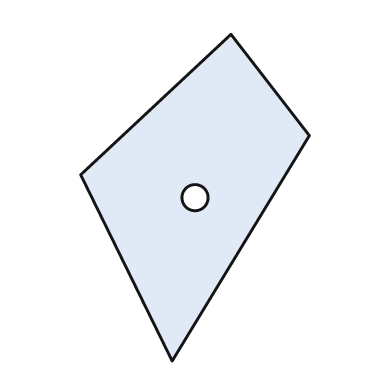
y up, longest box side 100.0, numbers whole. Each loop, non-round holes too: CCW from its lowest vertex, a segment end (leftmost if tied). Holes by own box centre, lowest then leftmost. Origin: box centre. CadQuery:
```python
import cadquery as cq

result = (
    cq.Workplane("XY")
    .moveTo(-7.0, -50.0)
    .lineTo(35.0, 19.0)
    .lineTo(11.0, 50.0)
    .lineTo(-35.0, 7.0)
    .close()
    .moveTo(0.0, 0.0)
    .circle(4.0)
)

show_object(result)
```